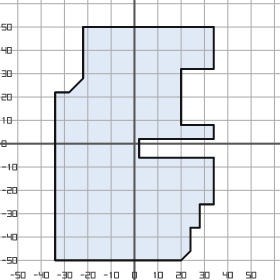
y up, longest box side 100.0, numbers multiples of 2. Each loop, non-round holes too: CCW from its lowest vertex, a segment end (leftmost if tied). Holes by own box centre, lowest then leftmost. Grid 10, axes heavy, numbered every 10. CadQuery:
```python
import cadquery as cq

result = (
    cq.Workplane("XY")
    .moveTo(-34.0, -50.0)
    .lineTo(20.0, -50.0)
    .lineTo(24.0, -46.0)
    .lineTo(24.0, -36.0)
    .lineTo(28.0, -36.0)
    .lineTo(28.0, -26.0)
    .lineTo(34.0, -26.0)
    .lineTo(34.0, -6.0)
    .lineTo(2.0, -6.0)
    .lineTo(2.0, 2.0)
    .lineTo(34.0, 2.0)
    .lineTo(34.0, 8.0)
    .lineTo(20.0, 8.0)
    .lineTo(20.0, 32.0)
    .lineTo(34.0, 32.0)
    .lineTo(34.0, 50.0)
    .lineTo(-22.0, 50.0)
    .lineTo(-22.0, 28.0)
    .lineTo(-28.0, 22.0)
    .lineTo(-34.0, 22.0)
    .close()
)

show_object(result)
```